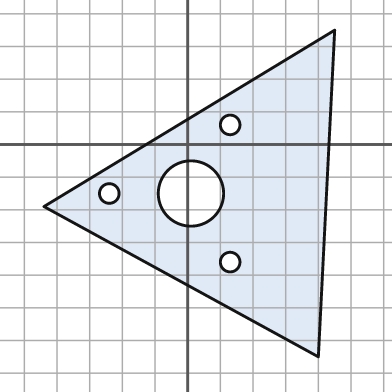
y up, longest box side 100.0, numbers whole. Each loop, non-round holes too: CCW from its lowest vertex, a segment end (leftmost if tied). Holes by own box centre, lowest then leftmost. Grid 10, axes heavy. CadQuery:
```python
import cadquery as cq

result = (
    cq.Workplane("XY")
    .moveTo(40.0, -65.0)
    .lineTo(45.0, 35.0)
    .lineTo(-44.0, -19.0)
    .close()
    .moveTo(13.0, -36.0)
    .circle(3.0)
    .moveTo(-24.0, -15.0)
    .circle(3.0)
    .moveTo(1.0, -15.0)
    .circle(10.0)
    .moveTo(13.0, 6.0)
    .circle(3.0)
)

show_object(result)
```